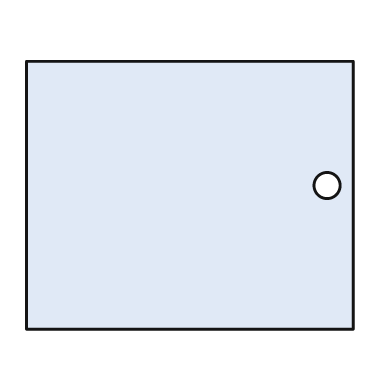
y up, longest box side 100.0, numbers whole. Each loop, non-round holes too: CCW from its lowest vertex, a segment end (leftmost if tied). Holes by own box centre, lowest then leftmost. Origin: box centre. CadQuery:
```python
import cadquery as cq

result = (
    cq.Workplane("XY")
    .moveTo(-50.0, -41.0)
    .lineTo(50.0, -41.0)
    .lineTo(50.0, 41.0)
    .lineTo(-50.0, 41.0)
    .close()
    .moveTo(42.0, 3.0)
    .circle(4.0)
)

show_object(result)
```